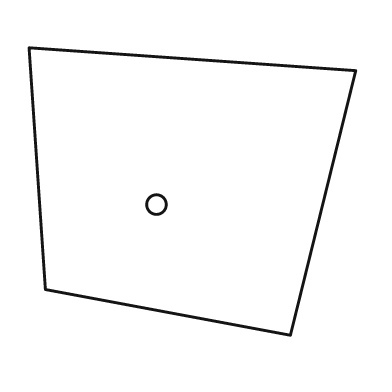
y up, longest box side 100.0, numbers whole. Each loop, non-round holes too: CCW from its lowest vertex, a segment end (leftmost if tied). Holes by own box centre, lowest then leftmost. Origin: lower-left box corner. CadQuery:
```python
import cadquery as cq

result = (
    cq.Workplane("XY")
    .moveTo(80.0, 0.0)
    .lineTo(100.0, 81.0)
    .lineTo(0.0, 88.0)
    .lineTo(5.0, 14.0)
    .close()
    .moveTo(39.0, 40.0)
    .circle(3.0)
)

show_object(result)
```